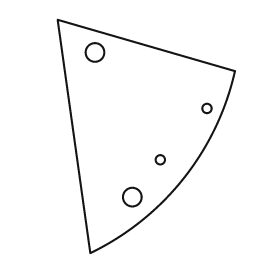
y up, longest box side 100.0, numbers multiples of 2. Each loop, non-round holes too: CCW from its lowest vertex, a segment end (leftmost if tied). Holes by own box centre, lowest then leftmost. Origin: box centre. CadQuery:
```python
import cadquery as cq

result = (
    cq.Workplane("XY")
    .moveTo(-24.0, -50.0)
    .threePointArc((16.0, -18.0), (38.0, 28.0))
    .lineTo(-38.0, 50.0)
    .close()
    .moveTo(-6.0, -26.0)
    .circle(4.0)
    .moveTo(6.0, -10.0)
    .circle(2.0)
    .moveTo(26.0, 12.0)
    .circle(2.0)
    .moveTo(-22.0, 36.0)
    .circle(4.0)
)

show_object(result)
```